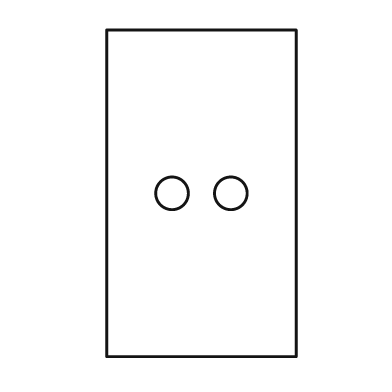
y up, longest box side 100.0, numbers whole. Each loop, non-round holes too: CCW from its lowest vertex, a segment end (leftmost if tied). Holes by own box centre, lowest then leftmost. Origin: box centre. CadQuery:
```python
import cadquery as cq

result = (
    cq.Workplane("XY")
    .moveTo(-29.0, -50.0)
    .lineTo(29.0, -50.0)
    .lineTo(29.0, 50.0)
    .lineTo(-29.0, 50.0)
    .close()
    .moveTo(-9.0, 0.0)
    .circle(5.0)
    .moveTo(9.0, 0.0)
    .circle(5.0)
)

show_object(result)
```